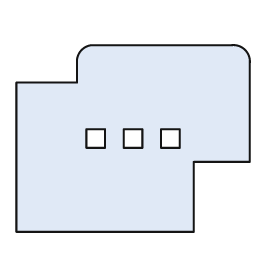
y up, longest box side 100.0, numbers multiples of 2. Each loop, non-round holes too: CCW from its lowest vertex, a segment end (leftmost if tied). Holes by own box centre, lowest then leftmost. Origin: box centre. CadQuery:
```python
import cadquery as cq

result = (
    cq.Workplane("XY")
    .moveTo(-50.0, -40.0)
    .lineTo(26.0, -40.0)
    .lineTo(26.0, -10.0)
    .lineTo(50.0, -10.0)
    .lineTo(50.0, 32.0)
    .threePointArc((48.0, 38.0), (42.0, 40.0))
    .lineTo(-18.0, 40.0)
    .threePointArc((-22.0, 38.0), (-24.0, 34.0))
    .lineTo(-24.0, 24.0)
    .lineTo(-50.0, 24.0)
    .close()
    .moveTo(-20.0, -4.0)
    .lineTo(-12.0, -4.0)
    .lineTo(-12.0, 4.0)
    .lineTo(-20.0, 4.0)
    .close()
    .moveTo(-4.0, -4.0)
    .lineTo(4.0, -4.0)
    .lineTo(4.0, 4.0)
    .lineTo(-4.0, 4.0)
    .close()
    .moveTo(12.0, -4.0)
    .lineTo(20.0, -4.0)
    .lineTo(20.0, 4.0)
    .lineTo(12.0, 4.0)
    .close()
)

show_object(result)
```